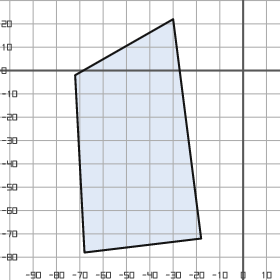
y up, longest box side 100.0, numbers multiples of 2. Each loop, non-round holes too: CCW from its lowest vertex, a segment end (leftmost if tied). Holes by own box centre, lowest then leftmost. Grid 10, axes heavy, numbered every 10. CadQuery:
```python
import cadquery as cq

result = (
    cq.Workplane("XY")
    .moveTo(-68.0, -78.0)
    .lineTo(-18.0, -72.0)
    .lineTo(-30.0, 22.0)
    .lineTo(-72.0, -2.0)
    .close()
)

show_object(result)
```